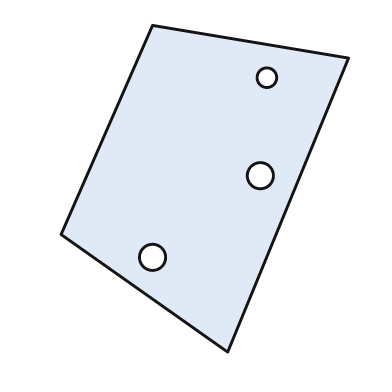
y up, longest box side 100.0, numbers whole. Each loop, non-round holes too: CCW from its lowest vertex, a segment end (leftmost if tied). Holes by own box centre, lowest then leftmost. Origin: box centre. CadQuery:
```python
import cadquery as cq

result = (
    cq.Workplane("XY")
    .moveTo(7.0, -50.0)
    .lineTo(44.0, 40.0)
    .lineTo(-16.0, 50.0)
    .lineTo(-44.0, -14.0)
    .close()
    .moveTo(-16.0, -21.0)
    .circle(4.0)
    .moveTo(17.0, 4.0)
    .circle(4.0)
    .moveTo(19.0, 34.0)
    .circle(3.0)
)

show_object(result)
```